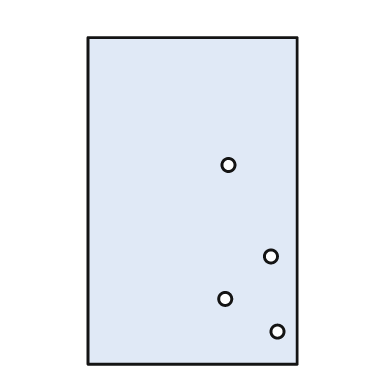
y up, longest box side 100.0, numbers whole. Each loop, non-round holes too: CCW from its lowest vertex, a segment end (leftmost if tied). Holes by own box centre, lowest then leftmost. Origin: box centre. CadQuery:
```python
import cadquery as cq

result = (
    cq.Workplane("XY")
    .moveTo(-32.0, -50.0)
    .lineTo(32.0, -50.0)
    .lineTo(32.0, 50.0)
    .lineTo(-32.0, 50.0)
    .close()
    .moveTo(26.0, -40.0)
    .circle(2.0)
    .moveTo(10.0, -30.0)
    .circle(2.0)
    .moveTo(24.0, -17.0)
    .circle(2.0)
    .moveTo(11.0, 11.0)
    .circle(2.0)
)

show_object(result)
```